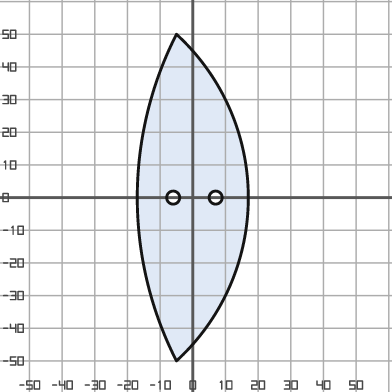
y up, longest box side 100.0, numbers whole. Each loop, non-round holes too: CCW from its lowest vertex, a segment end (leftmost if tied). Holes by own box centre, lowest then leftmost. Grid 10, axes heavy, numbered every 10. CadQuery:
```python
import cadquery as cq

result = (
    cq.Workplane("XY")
    .moveTo(-5.0, -50.0)
    .threePointArc((17.0, 0.0), (-5.0, 50.0))
    .threePointArc((-17.0, 0.0), (-5.0, -50.0))
    .close()
    .moveTo(-6.0, 0.0)
    .circle(2.0)
    .moveTo(7.0, 0.0)
    .circle(2.0)
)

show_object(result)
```